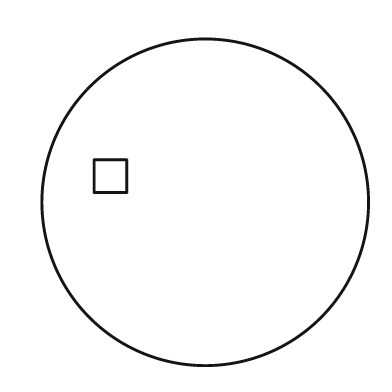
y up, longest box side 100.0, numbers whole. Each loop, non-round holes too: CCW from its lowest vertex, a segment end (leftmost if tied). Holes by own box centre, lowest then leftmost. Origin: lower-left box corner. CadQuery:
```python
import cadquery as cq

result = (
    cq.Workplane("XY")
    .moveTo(50.0, 50.0)
    .circle(50.0)
    .moveTo(16.0, 53.0)
    .lineTo(26.0, 53.0)
    .lineTo(26.0, 63.0)
    .lineTo(16.0, 63.0)
    .close()
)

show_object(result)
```